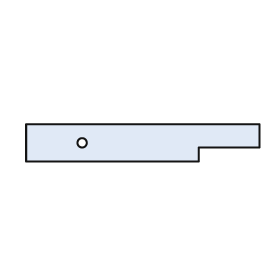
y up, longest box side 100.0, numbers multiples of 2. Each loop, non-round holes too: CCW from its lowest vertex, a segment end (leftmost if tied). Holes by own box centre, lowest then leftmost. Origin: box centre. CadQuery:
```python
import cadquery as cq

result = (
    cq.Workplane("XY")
    .moveTo(-50.0, -8.0)
    .lineTo(24.0, -8.0)
    .lineTo(24.0, -2.0)
    .lineTo(50.0, -2.0)
    .lineTo(50.0, 8.0)
    .lineTo(-50.0, 8.0)
    .close()
    .moveTo(-26.0, 0.0)
    .circle(2.0)
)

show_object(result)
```